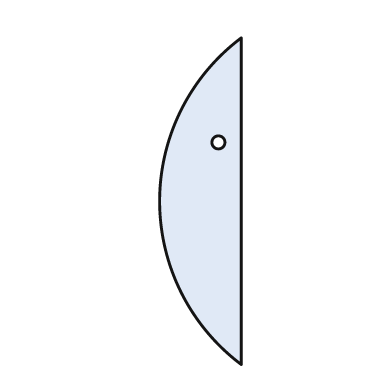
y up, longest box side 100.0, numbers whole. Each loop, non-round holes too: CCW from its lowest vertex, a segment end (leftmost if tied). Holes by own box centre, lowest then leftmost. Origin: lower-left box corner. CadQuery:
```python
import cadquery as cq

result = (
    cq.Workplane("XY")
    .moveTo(25.0, 0.0)
    .lineTo(25.0, 100.0)
    .threePointArc((0.0, 50.0), (25.0, 0.0))
    .close()
    .moveTo(18.0, 68.0)
    .circle(2.0)
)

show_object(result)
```